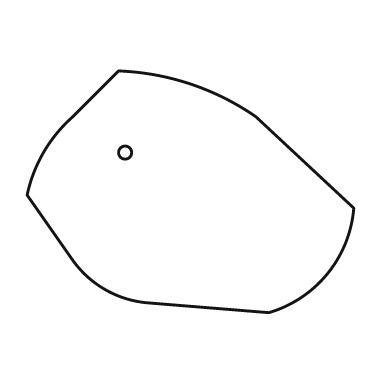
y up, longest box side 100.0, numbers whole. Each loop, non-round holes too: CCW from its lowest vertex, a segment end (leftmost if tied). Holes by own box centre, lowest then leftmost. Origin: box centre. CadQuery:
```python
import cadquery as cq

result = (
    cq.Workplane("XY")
    .moveTo(24.0, -37.0)
    .threePointArc((42.0, -25.0), (50.0, -5.0))
    .lineTo(20.0, 23.0)
    .threePointArc((0.0, 33.0), (-22.0, 37.0))
    .lineTo(-36.0, 23.0)
    .threePointArc((-45.0, 12.0), (-50.0, -1.0))
    .lineTo(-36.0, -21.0)
    .threePointArc((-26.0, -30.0), (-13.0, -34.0))
    .close()
    .moveTo(-20.0, 12.0)
    .circle(2.0)
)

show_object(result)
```